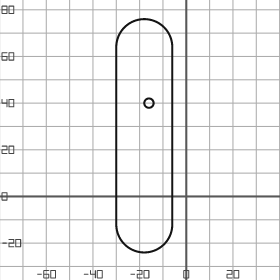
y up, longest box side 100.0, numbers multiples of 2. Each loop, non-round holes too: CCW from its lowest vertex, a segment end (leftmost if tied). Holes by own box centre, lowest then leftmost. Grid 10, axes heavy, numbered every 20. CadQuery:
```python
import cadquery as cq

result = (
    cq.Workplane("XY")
    .moveTo(-30.0, -12.0)
    .threePointArc((-18.0, -24.0), (-6.0, -12.0))
    .lineTo(-6.0, 64.0)
    .threePointArc((-18.0, 76.0), (-30.0, 64.0))
    .close()
    .moveTo(-16.0, 40.0)
    .circle(2.0)
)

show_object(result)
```